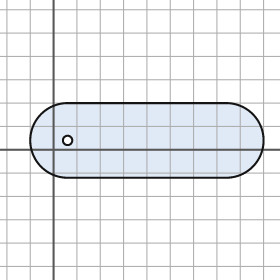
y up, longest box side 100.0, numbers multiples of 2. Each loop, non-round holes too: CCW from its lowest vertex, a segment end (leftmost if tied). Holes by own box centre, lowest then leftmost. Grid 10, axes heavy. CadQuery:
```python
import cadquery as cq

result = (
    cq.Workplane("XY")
    .moveTo(6.0, -12.0)
    .lineTo(74.0, -12.0)
    .threePointArc((90.0, 4.0), (74.0, 20.0))
    .lineTo(6.0, 20.0)
    .threePointArc((-10.0, 4.0), (6.0, -12.0))
    .close()
    .moveTo(6.0, 4.0)
    .circle(2.0)
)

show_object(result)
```